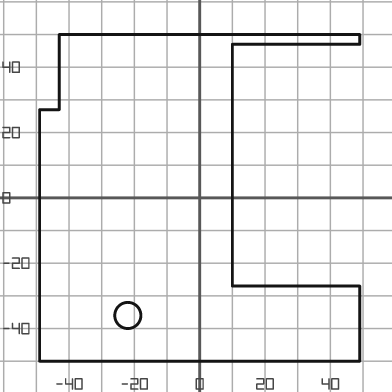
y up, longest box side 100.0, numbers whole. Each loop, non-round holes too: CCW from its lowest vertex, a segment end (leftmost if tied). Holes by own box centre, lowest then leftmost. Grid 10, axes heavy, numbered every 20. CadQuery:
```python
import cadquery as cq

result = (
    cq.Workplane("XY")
    .moveTo(-49.0, -50.0)
    .lineTo(49.0, -50.0)
    .lineTo(49.0, -27.0)
    .lineTo(10.0, -27.0)
    .lineTo(10.0, 47.0)
    .lineTo(49.0, 47.0)
    .lineTo(49.0, 50.0)
    .lineTo(-43.0, 50.0)
    .lineTo(-43.0, 27.0)
    .lineTo(-49.0, 27.0)
    .close()
    .moveTo(-22.0, -36.0)
    .circle(4.0)
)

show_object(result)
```